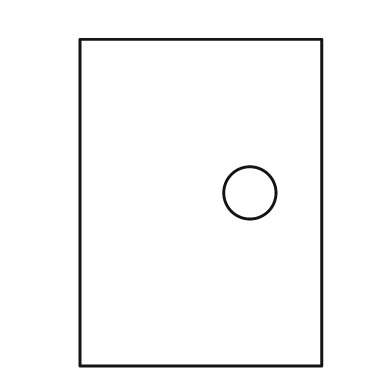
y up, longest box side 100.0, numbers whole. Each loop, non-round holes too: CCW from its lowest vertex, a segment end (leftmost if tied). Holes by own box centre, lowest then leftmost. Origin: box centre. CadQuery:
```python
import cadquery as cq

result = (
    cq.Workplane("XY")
    .moveTo(-37.0, -50.0)
    .lineTo(37.0, -50.0)
    .lineTo(37.0, 50.0)
    .lineTo(-37.0, 50.0)
    .close()
    .moveTo(15.0, 3.0)
    .circle(8.0)
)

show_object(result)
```